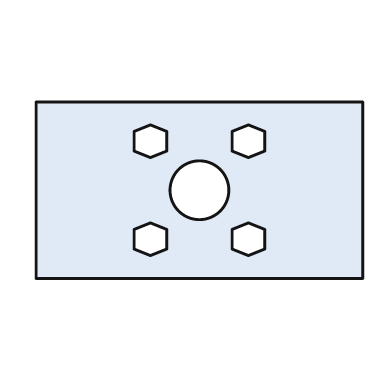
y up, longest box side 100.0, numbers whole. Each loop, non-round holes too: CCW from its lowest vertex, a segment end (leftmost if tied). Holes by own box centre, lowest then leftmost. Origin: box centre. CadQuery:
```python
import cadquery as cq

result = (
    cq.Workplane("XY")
    .moveTo(-50.0, -27.0)
    .lineTo(50.0, -27.0)
    .lineTo(50.0, 27.0)
    .lineTo(-50.0, 27.0)
    .close()
    .moveTo(-15.0, -20.0)
    .lineTo(-10.0, -18.0)
    .lineTo(-10.0, -12.0)
    .lineTo(-15.0, -10.0)
    .lineTo(-20.0, -12.0)
    .lineTo(-20.0, -18.0)
    .close()
    .moveTo(15.0, -20.0)
    .lineTo(20.0, -18.0)
    .lineTo(20.0, -12.0)
    .lineTo(15.0, -10.0)
    .lineTo(10.0, -12.0)
    .lineTo(10.0, -18.0)
    .close()
    .moveTo(0.0, 0.0)
    .circle(9.0)
    .moveTo(-15.0, 10.0)
    .lineTo(-10.0, 12.0)
    .lineTo(-10.0, 18.0)
    .lineTo(-15.0, 20.0)
    .lineTo(-20.0, 18.0)
    .lineTo(-20.0, 12.0)
    .close()
    .moveTo(15.0, 10.0)
    .lineTo(20.0, 12.0)
    .lineTo(20.0, 18.0)
    .lineTo(15.0, 20.0)
    .lineTo(10.0, 18.0)
    .lineTo(10.0, 12.0)
    .close()
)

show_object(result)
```